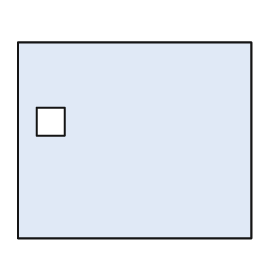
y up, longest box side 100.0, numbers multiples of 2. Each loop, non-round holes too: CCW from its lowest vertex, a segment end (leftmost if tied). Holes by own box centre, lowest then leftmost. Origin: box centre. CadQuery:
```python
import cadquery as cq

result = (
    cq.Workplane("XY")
    .moveTo(-50.0, -42.0)
    .lineTo(50.0, -42.0)
    .lineTo(50.0, 42.0)
    .lineTo(-50.0, 42.0)
    .close()
    .moveTo(-42.0, 2.0)
    .lineTo(-30.0, 2.0)
    .lineTo(-30.0, 14.0)
    .lineTo(-42.0, 14.0)
    .close()
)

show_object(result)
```